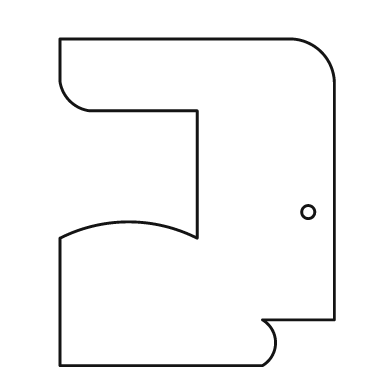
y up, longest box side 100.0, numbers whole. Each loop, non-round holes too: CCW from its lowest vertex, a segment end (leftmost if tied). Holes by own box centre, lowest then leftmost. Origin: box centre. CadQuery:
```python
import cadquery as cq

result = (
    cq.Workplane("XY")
    .moveTo(-42.0, -50.0)
    .lineTo(20.0, -50.0)
    .threePointArc((24.0, -43.0), (20.0, -36.0))
    .lineTo(42.0, -36.0)
    .lineTo(42.0, 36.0)
    .threePointArc((38.0, 46.0), (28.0, 50.0))
    .lineTo(-42.0, 50.0)
    .lineTo(-42.0, 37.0)
    .threePointArc((-39.0, 31.0), (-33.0, 28.0))
    .lineTo(0.0, 28.0)
    .lineTo(0.0, -11.0)
    .threePointArc((-21.0, -6.0), (-42.0, -11.0))
    .close()
    .moveTo(34.0, -3.0)
    .circle(2.0)
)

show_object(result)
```